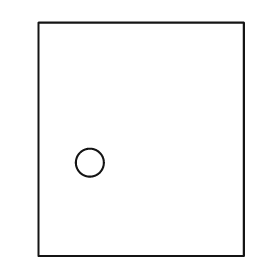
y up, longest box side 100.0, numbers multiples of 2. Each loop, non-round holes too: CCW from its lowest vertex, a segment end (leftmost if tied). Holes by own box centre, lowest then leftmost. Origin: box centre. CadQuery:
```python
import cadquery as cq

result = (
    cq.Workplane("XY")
    .moveTo(-44.0, -50.0)
    .lineTo(44.0, -50.0)
    .lineTo(44.0, 50.0)
    .lineTo(-44.0, 50.0)
    .close()
    .moveTo(-22.0, -10.0)
    .circle(6.0)
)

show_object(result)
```